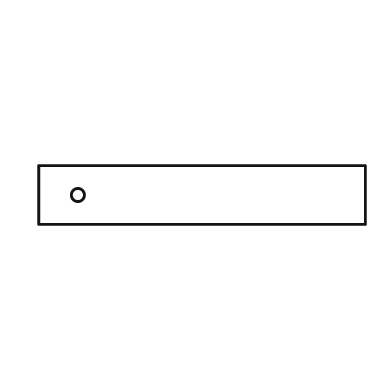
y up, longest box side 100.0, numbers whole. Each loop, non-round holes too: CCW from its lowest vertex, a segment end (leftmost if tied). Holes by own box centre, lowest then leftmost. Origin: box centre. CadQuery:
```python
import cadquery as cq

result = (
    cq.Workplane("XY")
    .moveTo(-50.0, -9.0)
    .lineTo(50.0, -9.0)
    .lineTo(50.0, 9.0)
    .lineTo(-50.0, 9.0)
    .close()
    .moveTo(-38.0, 0.0)
    .circle(2.0)
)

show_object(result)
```